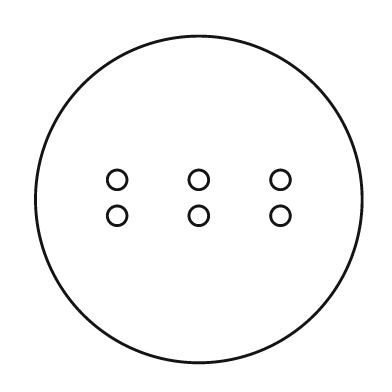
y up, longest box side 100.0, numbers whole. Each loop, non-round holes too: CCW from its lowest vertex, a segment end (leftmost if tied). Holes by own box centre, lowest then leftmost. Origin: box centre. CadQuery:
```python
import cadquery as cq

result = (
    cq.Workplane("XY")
    .moveTo(0.0, 0.0)
    .circle(50.0)
    .moveTo(-25.0, -5.0)
    .circle(3.0)
    .moveTo(0.0, -5.0)
    .circle(3.0)
    .moveTo(25.0, -5.0)
    .circle(3.0)
    .moveTo(-25.0, 6.0)
    .circle(3.0)
    .moveTo(0.0, 6.0)
    .circle(3.0)
    .moveTo(25.0, 6.0)
    .circle(3.0)
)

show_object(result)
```